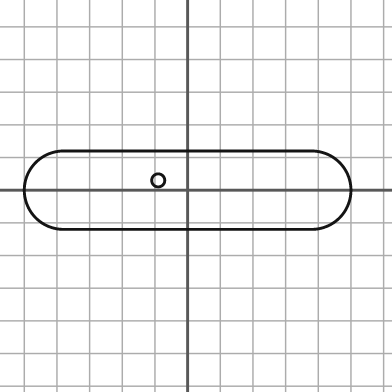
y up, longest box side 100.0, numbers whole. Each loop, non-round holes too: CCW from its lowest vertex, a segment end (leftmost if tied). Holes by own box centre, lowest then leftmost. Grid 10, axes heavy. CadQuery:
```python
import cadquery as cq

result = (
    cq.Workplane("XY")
    .moveTo(-38.0, -12.0)
    .lineTo(38.0, -12.0)
    .threePointArc((50.0, 0.0), (38.0, 12.0))
    .lineTo(-38.0, 12.0)
    .threePointArc((-50.0, 0.0), (-38.0, -12.0))
    .close()
    .moveTo(-9.0, 3.0)
    .circle(2.0)
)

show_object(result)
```